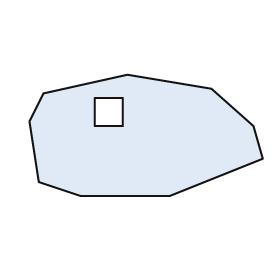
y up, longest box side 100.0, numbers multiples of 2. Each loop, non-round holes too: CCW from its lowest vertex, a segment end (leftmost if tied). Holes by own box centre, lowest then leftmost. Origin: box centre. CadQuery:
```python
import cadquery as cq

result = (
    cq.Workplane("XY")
    .moveTo(-28.0, -26.0)
    .lineTo(10.0, -26.0)
    .lineTo(50.0, -10.0)
    .lineTo(46.0, 4.0)
    .lineTo(28.0, 20.0)
    .lineTo(-8.0, 26.0)
    .lineTo(-44.0, 18.0)
    .lineTo(-50.0, 6.0)
    .lineTo(-46.0, -20.0)
    .close()
    .moveTo(-22.0, 4.0)
    .lineTo(-10.0, 4.0)
    .lineTo(-10.0, 16.0)
    .lineTo(-22.0, 16.0)
    .close()
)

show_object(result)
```